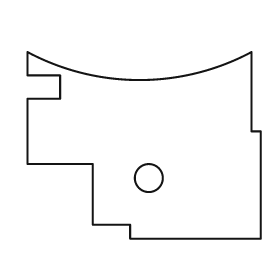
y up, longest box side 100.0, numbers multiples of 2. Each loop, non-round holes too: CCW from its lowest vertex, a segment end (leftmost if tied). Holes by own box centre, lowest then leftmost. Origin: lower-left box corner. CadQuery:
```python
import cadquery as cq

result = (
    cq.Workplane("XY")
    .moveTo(44.0, 0.0)
    .lineTo(100.0, 0.0)
    .lineTo(100.0, 46.0)
    .lineTo(96.0, 46.0)
    .lineTo(96.0, 80.0)
    .threePointArc((48.0, 68.0), (0.0, 80.0))
    .lineTo(0.0, 70.0)
    .lineTo(14.0, 70.0)
    .lineTo(14.0, 60.0)
    .lineTo(0.0, 60.0)
    .lineTo(0.0, 32.0)
    .lineTo(28.0, 32.0)
    .lineTo(28.0, 6.0)
    .lineTo(44.0, 6.0)
    .close()
    .moveTo(52.0, 26.0)
    .circle(6.0)
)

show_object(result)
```